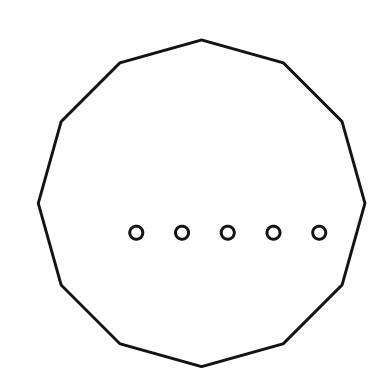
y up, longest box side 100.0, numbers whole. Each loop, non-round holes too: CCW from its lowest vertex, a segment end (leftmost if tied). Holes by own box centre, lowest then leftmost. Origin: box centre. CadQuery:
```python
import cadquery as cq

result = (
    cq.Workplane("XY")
    .moveTo(0.0, -50.0)
    .lineTo(25.0, -43.0)
    .lineTo(43.0, -25.0)
    .lineTo(50.0, 0.0)
    .lineTo(43.0, 25.0)
    .lineTo(25.0, 43.0)
    .lineTo(0.0, 50.0)
    .lineTo(-25.0, 43.0)
    .lineTo(-43.0, 25.0)
    .lineTo(-50.0, 0.0)
    .lineTo(-43.0, -25.0)
    .lineTo(-25.0, -43.0)
    .close()
    .moveTo(-20.0, -9.0)
    .circle(2.0)
    .moveTo(-6.0, -9.0)
    .circle(2.0)
    .moveTo(8.0, -9.0)
    .circle(2.0)
    .moveTo(22.0, -9.0)
    .circle(2.0)
    .moveTo(36.0, -9.0)
    .circle(2.0)
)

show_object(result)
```